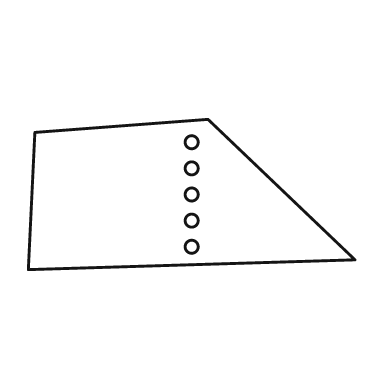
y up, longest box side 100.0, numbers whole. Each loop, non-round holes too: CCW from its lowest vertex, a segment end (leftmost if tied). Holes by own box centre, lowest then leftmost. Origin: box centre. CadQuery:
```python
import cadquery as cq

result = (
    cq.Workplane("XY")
    .moveTo(-50.0, -23.0)
    .lineTo(50.0, -20.0)
    .lineTo(5.0, 23.0)
    .lineTo(-48.0, 19.0)
    .close()
    .moveTo(0.0, -16.0)
    .circle(2.0)
    .moveTo(0.0, -8.0)
    .circle(2.0)
    .moveTo(0.0, 0.0)
    .circle(2.0)
    .moveTo(0.0, 8.0)
    .circle(2.0)
    .moveTo(0.0, 16.0)
    .circle(2.0)
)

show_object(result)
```